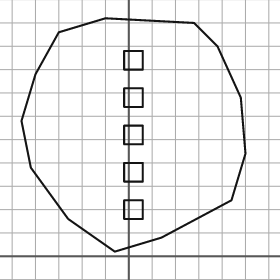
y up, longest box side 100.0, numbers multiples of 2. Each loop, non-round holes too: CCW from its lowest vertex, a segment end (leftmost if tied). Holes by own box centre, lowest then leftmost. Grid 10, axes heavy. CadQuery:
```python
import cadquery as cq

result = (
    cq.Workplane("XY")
    .moveTo(-6.0, 2.0)
    .lineTo(14.0, 8.0)
    .lineTo(44.0, 24.0)
    .lineTo(50.0, 44.0)
    .lineTo(48.0, 68.0)
    .lineTo(38.0, 90.0)
    .lineTo(28.0, 100.0)
    .lineTo(-10.0, 102.0)
    .lineTo(-30.0, 96.0)
    .lineTo(-40.0, 78.0)
    .lineTo(-46.0, 58.0)
    .lineTo(-42.0, 38.0)
    .lineTo(-26.0, 16.0)
    .close()
    .moveTo(-2.0, 16.0)
    .lineTo(6.0, 16.0)
    .lineTo(6.0, 24.0)
    .lineTo(-2.0, 24.0)
    .close()
    .moveTo(-2.0, 32.0)
    .lineTo(6.0, 32.0)
    .lineTo(6.0, 40.0)
    .lineTo(-2.0, 40.0)
    .close()
    .moveTo(-2.0, 48.0)
    .lineTo(6.0, 48.0)
    .lineTo(6.0, 56.0)
    .lineTo(-2.0, 56.0)
    .close()
    .moveTo(-2.0, 64.0)
    .lineTo(6.0, 64.0)
    .lineTo(6.0, 72.0)
    .lineTo(-2.0, 72.0)
    .close()
    .moveTo(-2.0, 80.0)
    .lineTo(6.0, 80.0)
    .lineTo(6.0, 88.0)
    .lineTo(-2.0, 88.0)
    .close()
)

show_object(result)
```